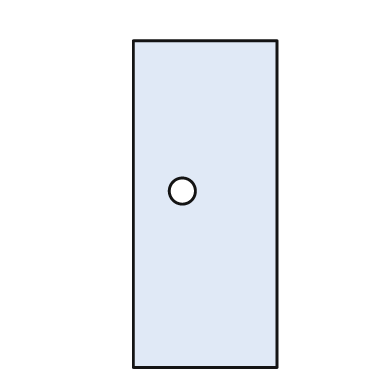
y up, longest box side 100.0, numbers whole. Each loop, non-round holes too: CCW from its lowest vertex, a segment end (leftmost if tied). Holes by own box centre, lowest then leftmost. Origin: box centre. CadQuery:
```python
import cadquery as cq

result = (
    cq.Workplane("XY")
    .moveTo(-22.0, -50.0)
    .lineTo(22.0, -50.0)
    .lineTo(22.0, 50.0)
    .lineTo(-22.0, 50.0)
    .close()
    .moveTo(-7.0, 4.0)
    .circle(4.0)
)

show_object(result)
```